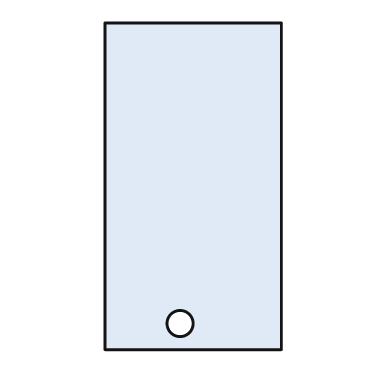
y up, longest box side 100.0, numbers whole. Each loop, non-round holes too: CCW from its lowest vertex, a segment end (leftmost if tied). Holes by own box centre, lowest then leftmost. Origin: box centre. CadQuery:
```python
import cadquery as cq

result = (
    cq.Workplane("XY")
    .moveTo(-27.0, -50.0)
    .lineTo(27.0, -50.0)
    .lineTo(27.0, 50.0)
    .lineTo(-27.0, 50.0)
    .close()
    .moveTo(-4.0, -42.0)
    .circle(4.0)
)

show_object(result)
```